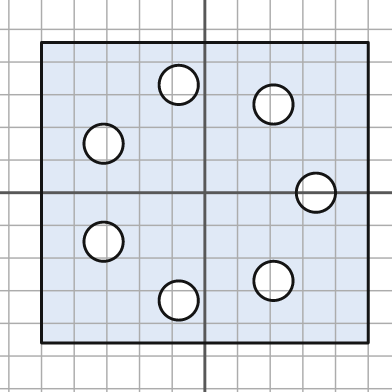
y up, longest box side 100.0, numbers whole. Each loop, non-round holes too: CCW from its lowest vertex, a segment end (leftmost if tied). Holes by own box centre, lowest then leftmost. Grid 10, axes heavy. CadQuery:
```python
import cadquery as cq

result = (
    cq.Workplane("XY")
    .moveTo(-50.0, -46.0)
    .lineTo(50.0, -46.0)
    .lineTo(50.0, 46.0)
    .lineTo(-50.0, 46.0)
    .close()
    .moveTo(-8.0, -33.0)
    .circle(6.0)
    .moveTo(21.0, -27.0)
    .circle(6.0)
    .moveTo(-31.0, -15.0)
    .circle(6.0)
    .moveTo(34.0, 0.0)
    .circle(6.0)
    .moveTo(-31.0, 15.0)
    .circle(6.0)
    .moveTo(21.0, 27.0)
    .circle(6.0)
    .moveTo(-8.0, 33.0)
    .circle(6.0)
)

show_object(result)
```